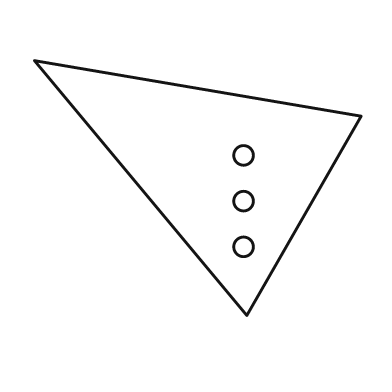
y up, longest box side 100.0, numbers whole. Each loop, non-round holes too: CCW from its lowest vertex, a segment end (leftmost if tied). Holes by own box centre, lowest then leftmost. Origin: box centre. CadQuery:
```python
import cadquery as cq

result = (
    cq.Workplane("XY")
    .moveTo(15.0, -39.0)
    .lineTo(50.0, 22.0)
    .lineTo(-50.0, 39.0)
    .close()
    .moveTo(14.0, -18.0)
    .circle(3.0)
    .moveTo(14.0, -4.0)
    .circle(3.0)
    .moveTo(14.0, 10.0)
    .circle(3.0)
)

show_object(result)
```